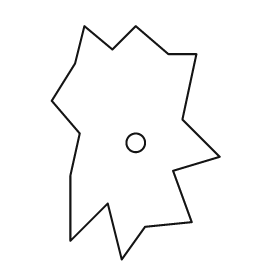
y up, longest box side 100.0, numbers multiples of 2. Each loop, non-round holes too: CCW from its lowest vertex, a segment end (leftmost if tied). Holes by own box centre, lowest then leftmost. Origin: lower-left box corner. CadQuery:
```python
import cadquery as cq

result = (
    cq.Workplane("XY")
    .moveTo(30.0, 0.0)
    .lineTo(40.0, 14.0)
    .lineTo(60.0, 16.0)
    .lineTo(52.0, 38.0)
    .lineTo(72.0, 44.0)
    .lineTo(56.0, 60.0)
    .lineTo(62.0, 88.0)
    .lineTo(50.0, 88.0)
    .lineTo(36.0, 100.0)
    .lineTo(26.0, 90.0)
    .lineTo(14.0, 100.0)
    .lineTo(10.0, 84.0)
    .lineTo(0.0, 68.0)
    .lineTo(12.0, 54.0)
    .lineTo(8.0, 36.0)
    .lineTo(8.0, 8.0)
    .lineTo(24.0, 24.0)
    .close()
    .moveTo(36.0, 50.0)
    .circle(4.0)
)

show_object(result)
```